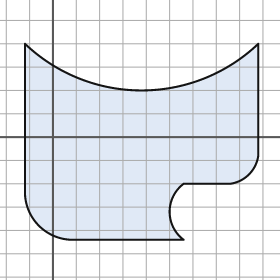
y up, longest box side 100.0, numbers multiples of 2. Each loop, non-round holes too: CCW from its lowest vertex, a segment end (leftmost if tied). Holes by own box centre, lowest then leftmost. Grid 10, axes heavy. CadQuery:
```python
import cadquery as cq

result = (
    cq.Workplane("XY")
    .moveTo(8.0, -44.0)
    .lineTo(56.0, -44.0)
    .threePointArc((50.0, -32.0), (56.0, -20.0))
    .lineTo(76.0, -20.0)
    .threePointArc((84.0, -16.0), (88.0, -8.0))
    .lineTo(88.0, 40.0)
    .threePointArc((38.0, 20.0), (-12.0, 40.0))
    .lineTo(-12.0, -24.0)
    .threePointArc((-6.0, -38.0), (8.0, -44.0))
    .close()
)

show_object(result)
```